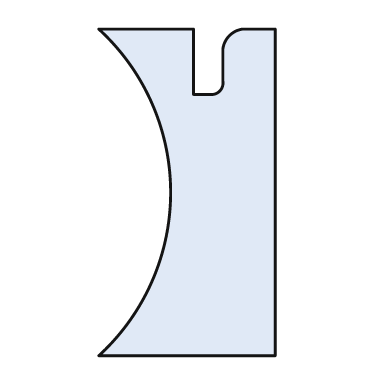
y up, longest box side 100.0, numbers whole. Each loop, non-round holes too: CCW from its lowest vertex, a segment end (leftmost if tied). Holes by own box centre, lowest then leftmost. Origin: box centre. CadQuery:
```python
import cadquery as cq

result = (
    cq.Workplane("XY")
    .moveTo(-27.0, -50.0)
    .lineTo(27.0, -50.0)
    .lineTo(27.0, 50.0)
    .lineTo(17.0, 50.0)
    .threePointArc((13.0, 48.0), (11.0, 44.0))
    .lineTo(11.0, 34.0)
    .threePointArc((10.0, 31.0), (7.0, 30.0))
    .lineTo(2.0, 30.0)
    .lineTo(2.0, 50.0)
    .lineTo(-27.0, 50.0)
    .threePointArc((-5.0, 0.0), (-27.0, -50.0))
    .close()
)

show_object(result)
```